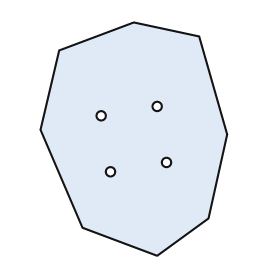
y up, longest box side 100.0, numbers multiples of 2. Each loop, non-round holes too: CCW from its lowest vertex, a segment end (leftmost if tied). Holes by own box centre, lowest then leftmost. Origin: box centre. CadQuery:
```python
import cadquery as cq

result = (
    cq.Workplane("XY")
    .moveTo(10.0, -50.0)
    .lineTo(32.0, -34.0)
    .lineTo(40.0, 2.0)
    .lineTo(28.0, 44.0)
    .lineTo(0.0, 50.0)
    .lineTo(-32.0, 38.0)
    .lineTo(-40.0, 4.0)
    .lineTo(-22.0, -38.0)
    .close()
    .moveTo(-10.0, -14.0)
    .circle(2.0)
    .moveTo(14.0, -10.0)
    .circle(2.0)
    .moveTo(-14.0, 10.0)
    .circle(2.0)
    .moveTo(10.0, 14.0)
    .circle(2.0)
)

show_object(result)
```